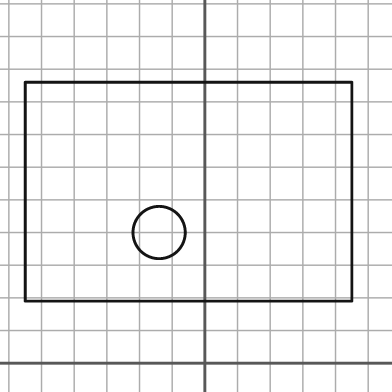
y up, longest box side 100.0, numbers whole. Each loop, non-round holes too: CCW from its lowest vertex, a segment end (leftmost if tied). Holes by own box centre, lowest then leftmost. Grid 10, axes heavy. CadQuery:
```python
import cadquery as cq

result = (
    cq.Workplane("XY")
    .moveTo(-55.0, 19.0)
    .lineTo(45.0, 19.0)
    .lineTo(45.0, 86.0)
    .lineTo(-55.0, 86.0)
    .close()
    .moveTo(-14.0, 40.0)
    .circle(8.0)
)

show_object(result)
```